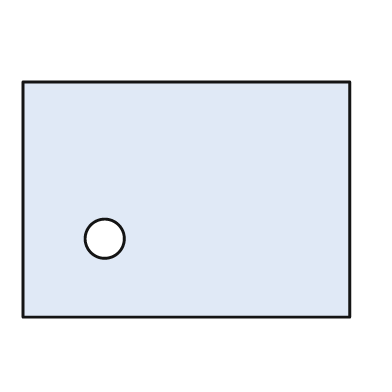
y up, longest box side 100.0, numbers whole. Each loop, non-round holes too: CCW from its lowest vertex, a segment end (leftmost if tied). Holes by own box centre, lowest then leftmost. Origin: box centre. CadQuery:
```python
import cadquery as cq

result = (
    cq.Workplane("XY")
    .moveTo(-50.0, -36.0)
    .lineTo(50.0, -36.0)
    .lineTo(50.0, 36.0)
    .lineTo(-50.0, 36.0)
    .close()
    .moveTo(-25.0, -12.0)
    .circle(6.0)
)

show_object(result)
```